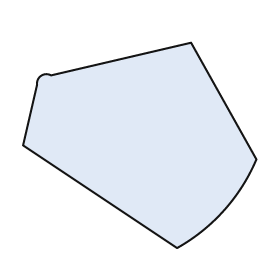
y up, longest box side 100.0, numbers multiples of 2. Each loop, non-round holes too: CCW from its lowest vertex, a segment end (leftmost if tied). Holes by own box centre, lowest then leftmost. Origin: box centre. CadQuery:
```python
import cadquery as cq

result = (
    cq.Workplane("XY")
    .moveTo(16.0, -44.0)
    .threePointArc((36.0, -28.0), (50.0, -6.0))
    .lineTo(22.0, 44.0)
    .lineTo(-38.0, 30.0)
    .threePointArc((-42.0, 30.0), (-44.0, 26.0))
    .lineTo(-50.0, 0.0)
    .close()
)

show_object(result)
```